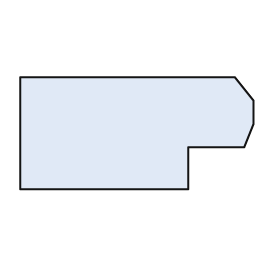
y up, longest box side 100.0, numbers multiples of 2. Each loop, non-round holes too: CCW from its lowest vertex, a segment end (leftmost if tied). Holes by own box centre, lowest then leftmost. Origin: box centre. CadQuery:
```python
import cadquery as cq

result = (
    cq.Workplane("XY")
    .moveTo(-50.0, -24.0)
    .lineTo(22.0, -24.0)
    .lineTo(22.0, -6.0)
    .lineTo(46.0, -6.0)
    .lineTo(50.0, 4.0)
    .lineTo(50.0, 14.0)
    .lineTo(42.0, 24.0)
    .lineTo(-50.0, 24.0)
    .close()
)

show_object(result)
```